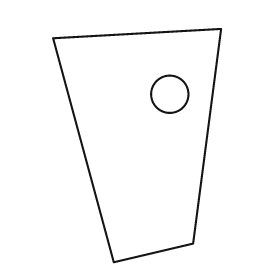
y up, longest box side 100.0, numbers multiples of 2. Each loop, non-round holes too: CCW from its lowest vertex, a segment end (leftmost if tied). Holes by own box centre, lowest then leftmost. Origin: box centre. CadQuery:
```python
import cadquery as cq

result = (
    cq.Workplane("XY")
    .moveTo(-10.0, -50.0)
    .lineTo(24.0, -42.0)
    .lineTo(36.0, 50.0)
    .lineTo(-36.0, 46.0)
    .close()
    .moveTo(14.0, 22.0)
    .circle(8.0)
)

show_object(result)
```